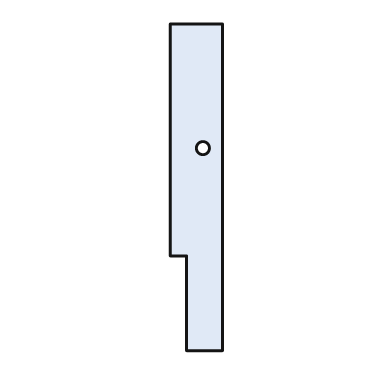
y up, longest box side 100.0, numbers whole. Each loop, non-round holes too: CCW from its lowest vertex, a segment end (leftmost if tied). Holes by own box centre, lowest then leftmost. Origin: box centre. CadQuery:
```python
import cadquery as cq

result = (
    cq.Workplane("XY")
    .moveTo(-3.0, -50.0)
    .lineTo(8.0, -50.0)
    .lineTo(8.0, 50.0)
    .lineTo(-8.0, 50.0)
    .lineTo(-8.0, -21.0)
    .lineTo(-3.0, -21.0)
    .close()
    .moveTo(2.0, 12.0)
    .circle(2.0)
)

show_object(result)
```